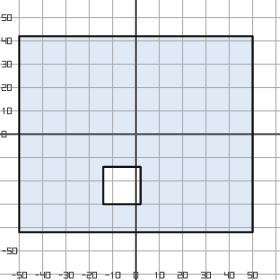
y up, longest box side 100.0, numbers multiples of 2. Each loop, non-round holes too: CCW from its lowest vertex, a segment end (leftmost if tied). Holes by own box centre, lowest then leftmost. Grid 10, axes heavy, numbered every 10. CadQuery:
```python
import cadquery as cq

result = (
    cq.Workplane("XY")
    .moveTo(-50.0, -42.0)
    .lineTo(50.0, -42.0)
    .lineTo(50.0, 42.0)
    .lineTo(-50.0, 42.0)
    .close()
    .moveTo(-14.0, -30.0)
    .lineTo(2.0, -30.0)
    .lineTo(2.0, -14.0)
    .lineTo(-14.0, -14.0)
    .close()
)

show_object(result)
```